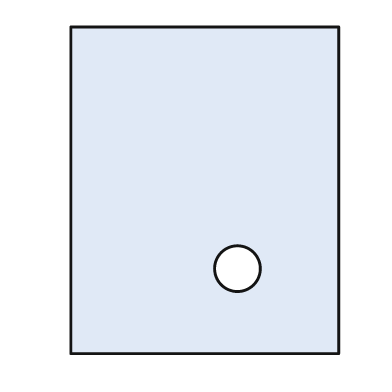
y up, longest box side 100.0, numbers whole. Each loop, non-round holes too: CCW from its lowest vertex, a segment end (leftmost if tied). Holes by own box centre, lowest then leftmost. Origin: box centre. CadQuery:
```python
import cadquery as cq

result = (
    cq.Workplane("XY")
    .moveTo(-41.0, -50.0)
    .lineTo(41.0, -50.0)
    .lineTo(41.0, 50.0)
    .lineTo(-41.0, 50.0)
    .close()
    .moveTo(10.0, -24.0)
    .circle(7.0)
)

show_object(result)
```